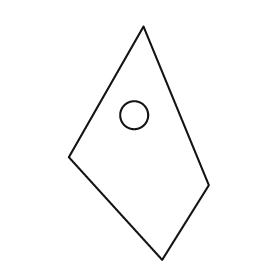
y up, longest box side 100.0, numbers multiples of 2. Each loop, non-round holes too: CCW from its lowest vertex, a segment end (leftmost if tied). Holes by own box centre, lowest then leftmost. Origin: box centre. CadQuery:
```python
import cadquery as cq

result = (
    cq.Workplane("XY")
    .moveTo(10.0, -50.0)
    .lineTo(30.0, -18.0)
    .lineTo(2.0, 50.0)
    .lineTo(-30.0, -6.0)
    .close()
    .moveTo(-2.0, 12.0)
    .circle(6.0)
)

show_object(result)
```